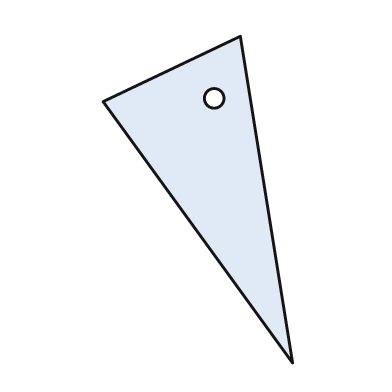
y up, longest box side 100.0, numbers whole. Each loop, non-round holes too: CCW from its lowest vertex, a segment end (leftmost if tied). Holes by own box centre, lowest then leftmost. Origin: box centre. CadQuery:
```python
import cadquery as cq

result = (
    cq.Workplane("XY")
    .moveTo(29.0, -50.0)
    .lineTo(13.0, 50.0)
    .lineTo(-29.0, 30.0)
    .close()
    .moveTo(5.0, 31.0)
    .circle(3.0)
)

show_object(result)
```